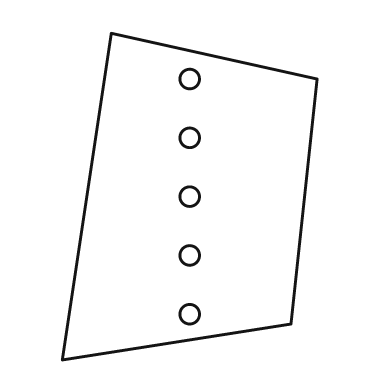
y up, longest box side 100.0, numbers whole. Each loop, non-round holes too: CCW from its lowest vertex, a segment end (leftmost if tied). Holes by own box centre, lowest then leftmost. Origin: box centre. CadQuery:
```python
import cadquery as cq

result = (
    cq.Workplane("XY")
    .moveTo(-39.0, -50.0)
    .lineTo(31.0, -39.0)
    .lineTo(39.0, 36.0)
    .lineTo(-24.0, 50.0)
    .close()
    .moveTo(0.0, -36.0)
    .circle(3.0)
    .moveTo(0.0, -18.0)
    .circle(3.0)
    .moveTo(0.0, 0.0)
    .circle(3.0)
    .moveTo(0.0, 18.0)
    .circle(3.0)
    .moveTo(0.0, 36.0)
    .circle(3.0)
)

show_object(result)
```